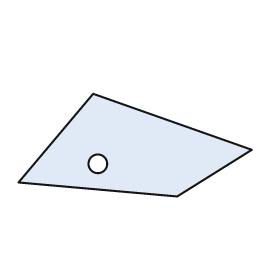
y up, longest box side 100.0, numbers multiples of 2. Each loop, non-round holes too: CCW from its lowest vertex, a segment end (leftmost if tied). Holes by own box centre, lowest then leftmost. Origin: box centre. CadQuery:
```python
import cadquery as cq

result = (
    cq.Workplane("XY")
    .moveTo(18.0, -22.0)
    .lineTo(50.0, -2.0)
    .lineTo(-18.0, 22.0)
    .lineTo(-50.0, -16.0)
    .close()
    .moveTo(-16.0, -8.0)
    .circle(4.0)
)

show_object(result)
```